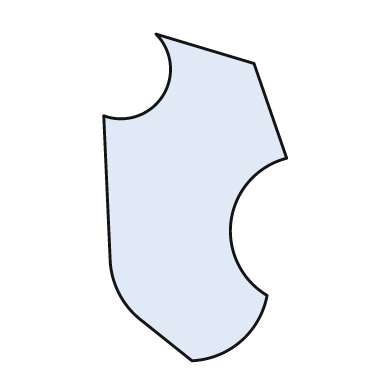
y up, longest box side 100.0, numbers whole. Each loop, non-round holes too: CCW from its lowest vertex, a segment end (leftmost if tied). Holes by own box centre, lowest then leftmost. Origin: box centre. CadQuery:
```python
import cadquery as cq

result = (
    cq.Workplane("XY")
    .moveTo(-1.0, -50.0)
    .threePointArc((14.0, -44.0), (22.0, -30.0))
    .threePointArc((11.0, -7.0), (28.0, 12.0))
    .lineTo(18.0, 41.0)
    .lineTo(-12.0, 50.0)
    .threePointArc((-10.0, 31.0), (-28.0, 25.0))
    .lineTo(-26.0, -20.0)
    .threePointArc((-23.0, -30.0), (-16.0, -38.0))
    .close()
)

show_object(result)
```